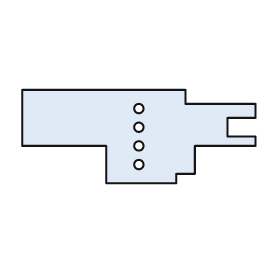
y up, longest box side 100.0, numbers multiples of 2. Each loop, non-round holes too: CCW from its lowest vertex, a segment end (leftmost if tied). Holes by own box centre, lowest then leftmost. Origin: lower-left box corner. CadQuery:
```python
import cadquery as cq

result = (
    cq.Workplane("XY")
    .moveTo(36.0, 0.0)
    .lineTo(66.0, 0.0)
    .lineTo(66.0, 4.0)
    .lineTo(74.0, 4.0)
    .lineTo(74.0, 16.0)
    .lineTo(100.0, 16.0)
    .lineTo(100.0, 20.0)
    .lineTo(88.0, 20.0)
    .lineTo(88.0, 28.0)
    .lineTo(100.0, 28.0)
    .lineTo(100.0, 34.0)
    .lineTo(70.0, 34.0)
    .lineTo(70.0, 40.0)
    .lineTo(0.0, 40.0)
    .lineTo(0.0, 16.0)
    .lineTo(36.0, 16.0)
    .close()
    .moveTo(50.0, 8.0)
    .circle(2.0)
    .moveTo(50.0, 16.0)
    .circle(2.0)
    .moveTo(50.0, 24.0)
    .circle(2.0)
    .moveTo(50.0, 32.0)
    .circle(2.0)
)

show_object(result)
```